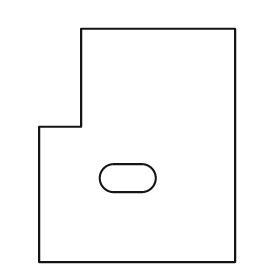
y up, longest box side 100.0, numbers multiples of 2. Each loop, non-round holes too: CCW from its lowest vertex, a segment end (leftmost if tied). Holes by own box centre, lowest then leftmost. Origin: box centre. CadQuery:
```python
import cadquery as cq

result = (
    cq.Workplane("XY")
    .moveTo(-42.0, -50.0)
    .lineTo(42.0, -50.0)
    .lineTo(42.0, 50.0)
    .lineTo(-24.0, 50.0)
    .lineTo(-24.0, 8.0)
    .lineTo(-42.0, 8.0)
    .close()
    .moveTo(-10.0, -20.0)
    .lineTo(2.0, -20.0)
    .threePointArc((8.0, -14.0), (2.0, -8.0))
    .lineTo(-10.0, -8.0)
    .threePointArc((-16.0, -14.0), (-10.0, -20.0))
    .close()
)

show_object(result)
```